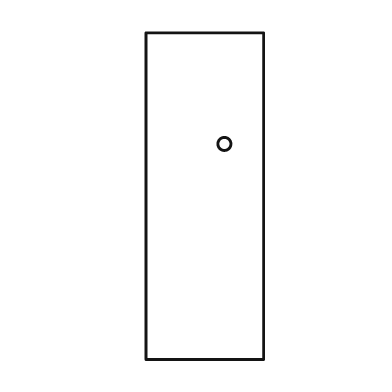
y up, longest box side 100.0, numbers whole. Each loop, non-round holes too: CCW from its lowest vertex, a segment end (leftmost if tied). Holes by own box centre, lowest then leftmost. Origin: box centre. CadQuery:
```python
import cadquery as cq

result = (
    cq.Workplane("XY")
    .moveTo(-18.0, -50.0)
    .lineTo(18.0, -50.0)
    .lineTo(18.0, 50.0)
    .lineTo(-18.0, 50.0)
    .close()
    .moveTo(6.0, 16.0)
    .circle(2.0)
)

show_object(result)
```